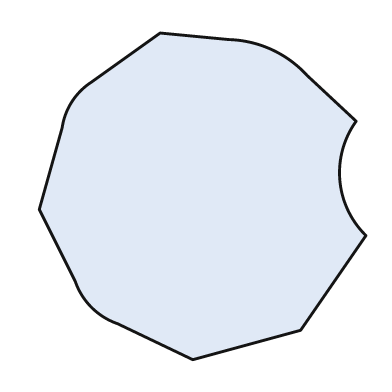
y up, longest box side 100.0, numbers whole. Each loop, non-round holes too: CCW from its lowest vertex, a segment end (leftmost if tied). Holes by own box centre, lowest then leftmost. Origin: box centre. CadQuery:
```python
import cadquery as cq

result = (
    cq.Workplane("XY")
    .moveTo(-3.0, -50.0)
    .lineTo(30.0, -41.0)
    .lineTo(50.0, -12.0)
    .threePointArc((42.0, 5.0), (47.0, 23.0))
    .lineTo(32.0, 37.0)
    .threePointArc((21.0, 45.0), (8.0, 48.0))
    .lineTo(-13.0, 50.0)
    .lineTo(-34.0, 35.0)
    .threePointArc((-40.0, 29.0), (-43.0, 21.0))
    .lineTo(-50.0, -4.0)
    .lineTo(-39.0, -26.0)
    .threePointArc((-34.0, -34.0), (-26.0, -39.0))
    .close()
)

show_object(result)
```